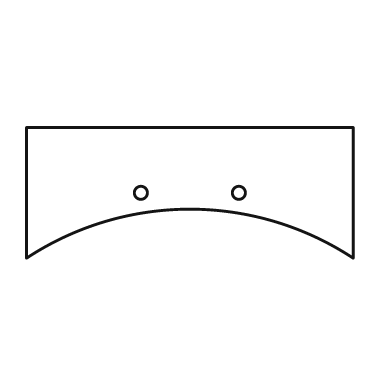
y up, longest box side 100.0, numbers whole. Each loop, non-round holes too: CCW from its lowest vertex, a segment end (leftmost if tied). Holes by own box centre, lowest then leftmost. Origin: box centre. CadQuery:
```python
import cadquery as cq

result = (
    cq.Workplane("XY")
    .moveTo(-50.0, -20.0)
    .threePointArc((0.0, -5.0), (50.0, -20.0))
    .lineTo(50.0, 20.0)
    .lineTo(-50.0, 20.0)
    .close()
    .moveTo(-15.0, 0.0)
    .circle(2.0)
    .moveTo(15.0, 0.0)
    .circle(2.0)
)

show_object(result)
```